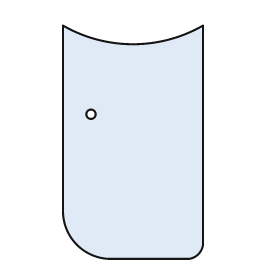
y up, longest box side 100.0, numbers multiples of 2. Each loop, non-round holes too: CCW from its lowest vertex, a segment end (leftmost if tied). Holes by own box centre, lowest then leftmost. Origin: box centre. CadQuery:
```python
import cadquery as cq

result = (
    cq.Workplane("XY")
    .moveTo(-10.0, -50.0)
    .lineTo(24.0, -50.0)
    .threePointArc((28.0, -48.0), (30.0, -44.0))
    .lineTo(30.0, 50.0)
    .threePointArc((0.0, 42.0), (-30.0, 50.0))
    .lineTo(-30.0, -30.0)
    .threePointArc((-24.0, -44.0), (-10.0, -50.0))
    .close()
    .moveTo(-18.0, 12.0)
    .circle(2.0)
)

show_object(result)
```